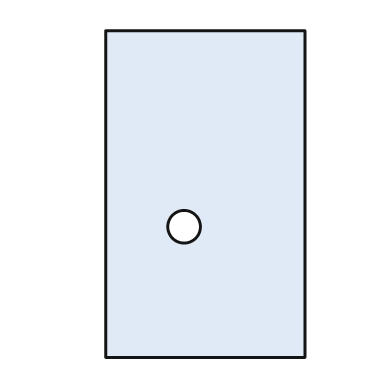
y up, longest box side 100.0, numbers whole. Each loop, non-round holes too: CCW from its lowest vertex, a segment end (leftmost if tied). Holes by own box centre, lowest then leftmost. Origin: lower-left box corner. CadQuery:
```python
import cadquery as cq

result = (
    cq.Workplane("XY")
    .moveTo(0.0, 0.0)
    .lineTo(61.0, 0.0)
    .lineTo(61.0, 100.0)
    .lineTo(0.0, 100.0)
    .close()
    .moveTo(24.0, 40.0)
    .circle(5.0)
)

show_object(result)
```